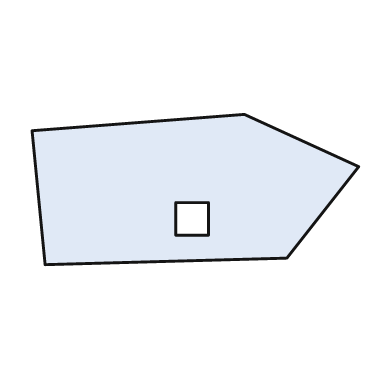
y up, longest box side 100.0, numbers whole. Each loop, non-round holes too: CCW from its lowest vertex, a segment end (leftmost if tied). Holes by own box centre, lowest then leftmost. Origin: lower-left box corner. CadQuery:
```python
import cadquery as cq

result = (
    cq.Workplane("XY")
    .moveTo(4.0, 0.0)
    .lineTo(78.0, 2.0)
    .lineTo(100.0, 30.0)
    .lineTo(65.0, 46.0)
    .lineTo(0.0, 41.0)
    .close()
    .moveTo(44.0, 9.0)
    .lineTo(54.0, 9.0)
    .lineTo(54.0, 19.0)
    .lineTo(44.0, 19.0)
    .close()
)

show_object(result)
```